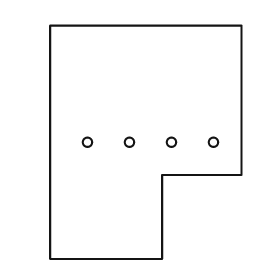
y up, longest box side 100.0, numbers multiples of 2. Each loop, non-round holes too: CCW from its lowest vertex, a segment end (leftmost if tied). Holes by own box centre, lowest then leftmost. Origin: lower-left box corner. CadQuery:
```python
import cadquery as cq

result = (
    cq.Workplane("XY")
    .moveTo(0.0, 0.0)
    .lineTo(48.0, 0.0)
    .lineTo(48.0, 36.0)
    .lineTo(82.0, 36.0)
    .lineTo(82.0, 100.0)
    .lineTo(0.0, 100.0)
    .close()
    .moveTo(16.0, 50.0)
    .circle(2.0)
    .moveTo(34.0, 50.0)
    .circle(2.0)
    .moveTo(52.0, 50.0)
    .circle(2.0)
    .moveTo(70.0, 50.0)
    .circle(2.0)
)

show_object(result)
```